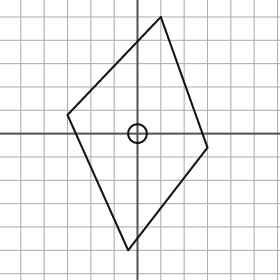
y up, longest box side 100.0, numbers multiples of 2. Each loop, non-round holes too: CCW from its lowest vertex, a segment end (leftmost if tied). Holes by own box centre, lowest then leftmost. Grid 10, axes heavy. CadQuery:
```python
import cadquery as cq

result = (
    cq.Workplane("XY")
    .moveTo(-4.0, -50.0)
    .lineTo(30.0, -6.0)
    .lineTo(10.0, 50.0)
    .lineTo(-30.0, 8.0)
    .close()
    .moveTo(0.0, 0.0)
    .circle(4.0)
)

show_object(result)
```